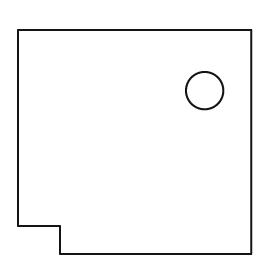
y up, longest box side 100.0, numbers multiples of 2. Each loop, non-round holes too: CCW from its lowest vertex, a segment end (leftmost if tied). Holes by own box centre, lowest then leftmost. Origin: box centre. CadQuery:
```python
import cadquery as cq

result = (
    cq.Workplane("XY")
    .moveTo(-32.0, -48.0)
    .lineTo(50.0, -48.0)
    .lineTo(50.0, 48.0)
    .lineTo(-50.0, 48.0)
    .lineTo(-50.0, -36.0)
    .lineTo(-32.0, -36.0)
    .close()
    .moveTo(30.0, 22.0)
    .circle(8.0)
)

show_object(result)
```